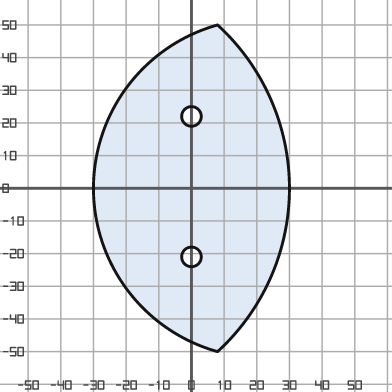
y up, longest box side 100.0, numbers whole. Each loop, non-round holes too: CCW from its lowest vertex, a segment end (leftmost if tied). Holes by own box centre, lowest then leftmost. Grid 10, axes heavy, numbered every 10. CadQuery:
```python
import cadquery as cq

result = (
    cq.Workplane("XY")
    .moveTo(8.0, -50.0)
    .threePointArc((30.0, 0.0), (8.0, 50.0))
    .threePointArc((-30.0, 0.0), (8.0, -50.0))
    .close()
    .moveTo(0.0, -21.0)
    .circle(3.0)
    .moveTo(0.0, 22.0)
    .circle(3.0)
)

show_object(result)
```